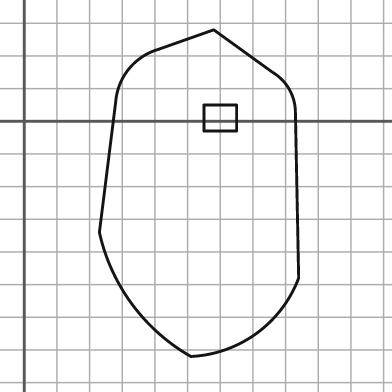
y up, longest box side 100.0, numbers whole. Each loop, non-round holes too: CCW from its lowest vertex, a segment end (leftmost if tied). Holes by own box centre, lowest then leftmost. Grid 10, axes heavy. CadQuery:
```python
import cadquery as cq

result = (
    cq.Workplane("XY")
    .moveTo(51.0, -72.0)
    .threePointArc((71.0, -65.0), (84.0, -48.0))
    .lineTo(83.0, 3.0)
    .threePointArc((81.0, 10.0), (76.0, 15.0))
    .lineTo(58.0, 28.0)
    .lineTo(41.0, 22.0)
    .threePointArc((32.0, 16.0), (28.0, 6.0))
    .lineTo(23.0, -34.0)
    .threePointArc((33.0, -56.0), (51.0, -72.0))
    .close()
    .moveTo(55.0, -3.0)
    .lineTo(65.0, -3.0)
    .lineTo(65.0, 5.0)
    .lineTo(55.0, 5.0)
    .close()
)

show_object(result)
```